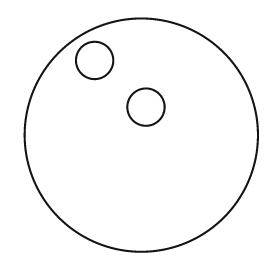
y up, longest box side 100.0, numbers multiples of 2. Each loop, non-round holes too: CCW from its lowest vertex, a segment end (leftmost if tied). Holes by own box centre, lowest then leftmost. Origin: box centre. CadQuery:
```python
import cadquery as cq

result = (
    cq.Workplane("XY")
    .moveTo(0.0, 0.0)
    .circle(50.0)
    .moveTo(2.0, 12.0)
    .circle(8.0)
    .moveTo(-20.0, 32.0)
    .circle(8.0)
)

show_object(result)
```